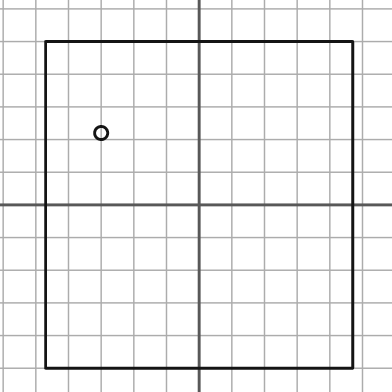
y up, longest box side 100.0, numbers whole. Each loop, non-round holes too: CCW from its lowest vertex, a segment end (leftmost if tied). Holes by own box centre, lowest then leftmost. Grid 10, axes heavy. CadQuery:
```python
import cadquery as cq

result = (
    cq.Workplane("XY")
    .moveTo(-47.0, -50.0)
    .lineTo(47.0, -50.0)
    .lineTo(47.0, 50.0)
    .lineTo(-47.0, 50.0)
    .close()
    .moveTo(-30.0, 22.0)
    .circle(2.0)
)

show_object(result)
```